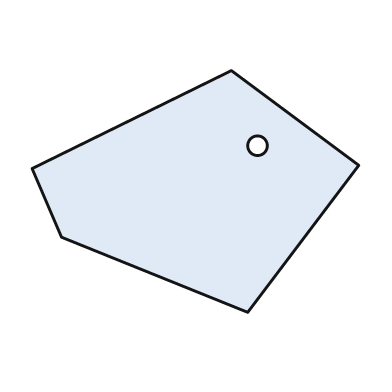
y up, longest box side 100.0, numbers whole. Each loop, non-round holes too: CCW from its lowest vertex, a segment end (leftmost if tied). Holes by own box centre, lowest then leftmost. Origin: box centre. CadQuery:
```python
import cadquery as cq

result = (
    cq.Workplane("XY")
    .moveTo(16.0, -37.0)
    .lineTo(50.0, 8.0)
    .lineTo(11.0, 37.0)
    .lineTo(-50.0, 7.0)
    .lineTo(-41.0, -14.0)
    .close()
    .moveTo(19.0, 14.0)
    .circle(3.0)
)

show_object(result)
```